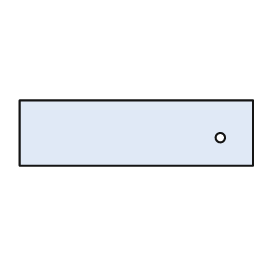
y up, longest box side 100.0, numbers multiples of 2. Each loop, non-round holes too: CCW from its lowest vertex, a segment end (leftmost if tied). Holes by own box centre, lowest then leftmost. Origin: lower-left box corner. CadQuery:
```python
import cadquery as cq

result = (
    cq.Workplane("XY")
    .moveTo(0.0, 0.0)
    .lineTo(100.0, 0.0)
    .lineTo(100.0, 28.0)
    .lineTo(0.0, 28.0)
    .close()
    .moveTo(86.0, 12.0)
    .circle(2.0)
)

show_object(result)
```